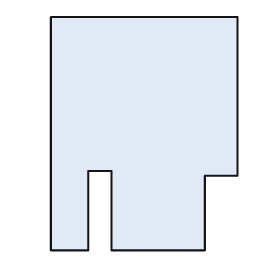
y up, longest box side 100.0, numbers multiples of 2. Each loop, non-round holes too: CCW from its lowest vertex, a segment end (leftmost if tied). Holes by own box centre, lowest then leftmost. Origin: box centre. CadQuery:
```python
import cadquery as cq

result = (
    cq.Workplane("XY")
    .moveTo(-40.0, -50.0)
    .lineTo(-24.0, -50.0)
    .lineTo(-24.0, -16.0)
    .lineTo(-14.0, -16.0)
    .lineTo(-14.0, -50.0)
    .lineTo(26.0, -50.0)
    .lineTo(26.0, -18.0)
    .lineTo(40.0, -18.0)
    .lineTo(40.0, 50.0)
    .lineTo(-40.0, 50.0)
    .close()
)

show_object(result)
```